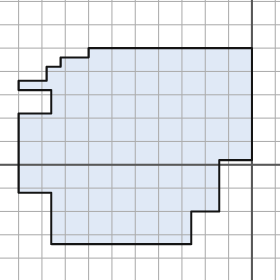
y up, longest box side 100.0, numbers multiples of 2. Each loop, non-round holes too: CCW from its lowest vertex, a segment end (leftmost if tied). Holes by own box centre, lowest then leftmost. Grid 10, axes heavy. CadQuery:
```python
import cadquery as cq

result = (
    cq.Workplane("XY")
    .moveTo(-86.0, -34.0)
    .lineTo(-26.0, -34.0)
    .lineTo(-26.0, -20.0)
    .lineTo(-14.0, -20.0)
    .lineTo(-14.0, 2.0)
    .lineTo(0.0, 2.0)
    .lineTo(0.0, 50.0)
    .lineTo(-70.0, 50.0)
    .lineTo(-70.0, 46.0)
    .lineTo(-82.0, 46.0)
    .lineTo(-82.0, 42.0)
    .lineTo(-88.0, 42.0)
    .lineTo(-88.0, 36.0)
    .lineTo(-100.0, 36.0)
    .lineTo(-100.0, 32.0)
    .lineTo(-86.0, 32.0)
    .lineTo(-86.0, 22.0)
    .lineTo(-100.0, 22.0)
    .lineTo(-100.0, -12.0)
    .lineTo(-86.0, -12.0)
    .close()
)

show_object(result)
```